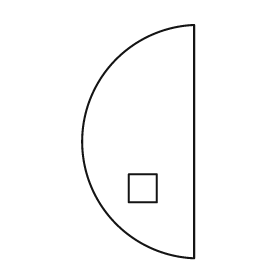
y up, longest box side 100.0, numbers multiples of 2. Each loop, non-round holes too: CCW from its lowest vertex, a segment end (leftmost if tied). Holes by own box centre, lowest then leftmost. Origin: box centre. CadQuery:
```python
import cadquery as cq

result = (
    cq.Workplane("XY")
    .moveTo(24.0, -50.0)
    .lineTo(24.0, 50.0)
    .threePointArc((-24.0, 0.0), (24.0, -50.0))
    .close()
    .moveTo(-4.0, -26.0)
    .lineTo(8.0, -26.0)
    .lineTo(8.0, -14.0)
    .lineTo(-4.0, -14.0)
    .close()
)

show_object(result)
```